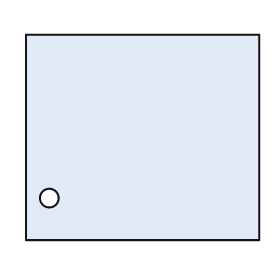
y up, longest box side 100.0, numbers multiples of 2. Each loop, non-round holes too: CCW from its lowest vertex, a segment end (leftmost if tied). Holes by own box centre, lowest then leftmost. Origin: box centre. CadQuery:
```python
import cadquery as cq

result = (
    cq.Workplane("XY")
    .moveTo(-50.0, -44.0)
    .lineTo(50.0, -44.0)
    .lineTo(50.0, 44.0)
    .lineTo(-50.0, 44.0)
    .close()
    .moveTo(-40.0, -26.0)
    .circle(4.0)
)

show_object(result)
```